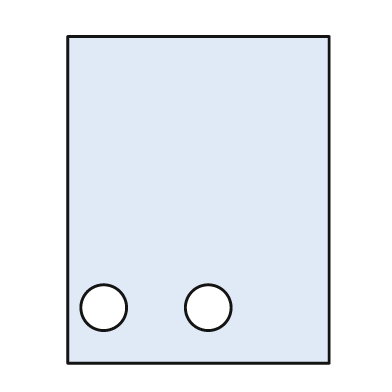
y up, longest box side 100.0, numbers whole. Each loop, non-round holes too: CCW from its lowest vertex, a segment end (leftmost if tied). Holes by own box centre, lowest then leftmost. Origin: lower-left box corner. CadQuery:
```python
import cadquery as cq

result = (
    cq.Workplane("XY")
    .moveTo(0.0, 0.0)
    .lineTo(80.0, 0.0)
    .lineTo(80.0, 100.0)
    .lineTo(0.0, 100.0)
    .close()
    .moveTo(11.0, 17.0)
    .circle(7.0)
    .moveTo(43.0, 17.0)
    .circle(7.0)
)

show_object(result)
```